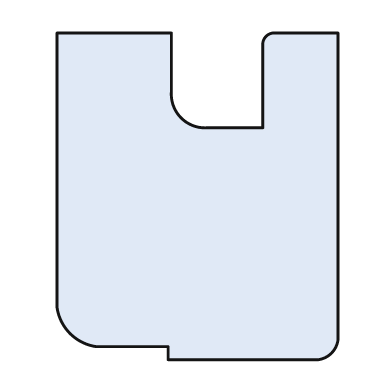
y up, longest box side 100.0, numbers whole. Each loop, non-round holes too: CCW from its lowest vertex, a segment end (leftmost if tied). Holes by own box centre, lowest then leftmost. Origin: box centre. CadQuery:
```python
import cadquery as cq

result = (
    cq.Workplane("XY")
    .moveTo(-9.0, -50.0)
    .lineTo(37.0, -50.0)
    .threePointArc((41.0, -48.0), (43.0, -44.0))
    .lineTo(43.0, 50.0)
    .lineTo(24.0, 50.0)
    .threePointArc((21.0, 49.0), (20.0, 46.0))
    .lineTo(20.0, 21.0)
    .lineTo(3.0, 21.0)
    .threePointArc((-5.0, 24.0), (-8.0, 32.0))
    .lineTo(-8.0, 50.0)
    .lineTo(-43.0, 50.0)
    .lineTo(-43.0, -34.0)
    .threePointArc((-39.0, -42.0), (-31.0, -46.0))
    .lineTo(-9.0, -46.0)
    .close()
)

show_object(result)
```